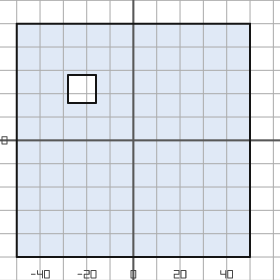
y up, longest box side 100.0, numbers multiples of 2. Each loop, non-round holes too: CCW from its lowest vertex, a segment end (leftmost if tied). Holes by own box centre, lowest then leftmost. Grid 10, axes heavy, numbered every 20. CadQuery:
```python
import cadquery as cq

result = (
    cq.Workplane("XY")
    .moveTo(-50.0, -50.0)
    .lineTo(50.0, -50.0)
    .lineTo(50.0, 50.0)
    .lineTo(-50.0, 50.0)
    .close()
    .moveTo(-28.0, 16.0)
    .lineTo(-16.0, 16.0)
    .lineTo(-16.0, 28.0)
    .lineTo(-28.0, 28.0)
    .close()
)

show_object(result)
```